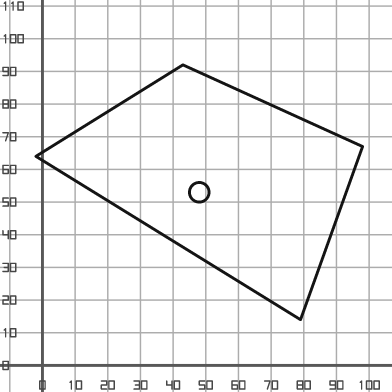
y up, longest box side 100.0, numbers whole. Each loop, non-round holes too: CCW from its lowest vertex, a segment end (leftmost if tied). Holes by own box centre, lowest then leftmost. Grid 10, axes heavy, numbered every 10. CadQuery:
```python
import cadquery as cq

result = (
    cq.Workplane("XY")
    .moveTo(79.0, 14.0)
    .lineTo(98.0, 67.0)
    .lineTo(43.0, 92.0)
    .lineTo(-2.0, 64.0)
    .close()
    .moveTo(48.0, 53.0)
    .circle(3.0)
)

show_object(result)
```